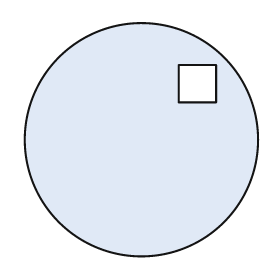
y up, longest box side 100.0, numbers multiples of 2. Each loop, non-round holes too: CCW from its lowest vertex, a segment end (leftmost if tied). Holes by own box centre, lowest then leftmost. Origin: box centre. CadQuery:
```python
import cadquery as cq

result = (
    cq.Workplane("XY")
    .moveTo(0.0, 0.0)
    .circle(50.0)
    .moveTo(16.0, 16.0)
    .lineTo(32.0, 16.0)
    .lineTo(32.0, 32.0)
    .lineTo(16.0, 32.0)
    .close()
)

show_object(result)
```